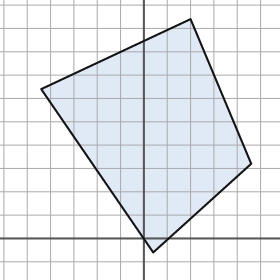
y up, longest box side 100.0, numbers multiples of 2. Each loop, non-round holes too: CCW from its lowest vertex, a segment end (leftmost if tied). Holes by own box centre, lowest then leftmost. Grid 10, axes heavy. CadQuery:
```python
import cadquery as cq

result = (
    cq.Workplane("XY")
    .moveTo(4.0, -6.0)
    .lineTo(46.0, 32.0)
    .lineTo(20.0, 94.0)
    .lineTo(-44.0, 64.0)
    .close()
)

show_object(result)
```